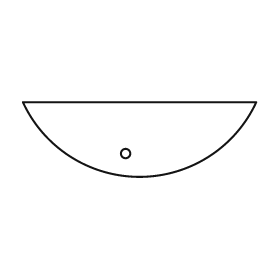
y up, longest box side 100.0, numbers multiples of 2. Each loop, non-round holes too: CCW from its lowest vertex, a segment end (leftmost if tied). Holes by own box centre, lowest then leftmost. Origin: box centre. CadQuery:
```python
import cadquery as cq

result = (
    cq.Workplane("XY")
    .moveTo(-50.0, 16.0)
    .threePointArc((0.0, -16.0), (50.0, 16.0))
    .close()
    .moveTo(-6.0, -6.0)
    .circle(2.0)
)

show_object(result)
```